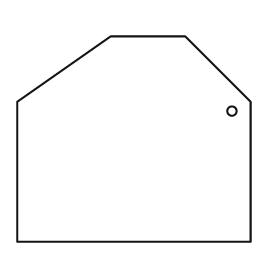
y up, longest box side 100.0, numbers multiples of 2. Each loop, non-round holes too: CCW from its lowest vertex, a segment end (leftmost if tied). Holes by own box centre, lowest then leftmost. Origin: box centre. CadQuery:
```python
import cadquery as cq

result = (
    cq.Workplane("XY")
    .moveTo(-50.0, -44.0)
    .lineTo(50.0, -44.0)
    .lineTo(50.0, 16.0)
    .lineTo(22.0, 44.0)
    .lineTo(-10.0, 44.0)
    .lineTo(-50.0, 16.0)
    .close()
    .moveTo(42.0, 12.0)
    .circle(2.0)
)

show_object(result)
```